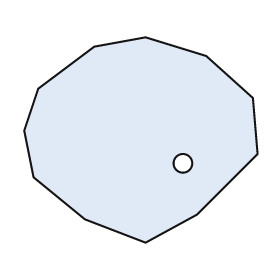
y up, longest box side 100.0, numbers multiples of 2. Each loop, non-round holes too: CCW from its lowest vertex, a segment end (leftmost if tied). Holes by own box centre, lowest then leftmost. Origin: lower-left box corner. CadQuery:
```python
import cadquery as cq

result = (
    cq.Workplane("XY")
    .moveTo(52.0, 0.0)
    .lineTo(74.0, 12.0)
    .lineTo(100.0, 38.0)
    .lineTo(98.0, 62.0)
    .lineTo(78.0, 80.0)
    .lineTo(52.0, 88.0)
    .lineTo(30.0, 84.0)
    .lineTo(6.0, 66.0)
    .lineTo(0.0, 48.0)
    .lineTo(4.0, 28.0)
    .lineTo(26.0, 10.0)
    .close()
    .moveTo(68.0, 34.0)
    .circle(4.0)
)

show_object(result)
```